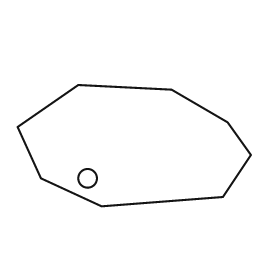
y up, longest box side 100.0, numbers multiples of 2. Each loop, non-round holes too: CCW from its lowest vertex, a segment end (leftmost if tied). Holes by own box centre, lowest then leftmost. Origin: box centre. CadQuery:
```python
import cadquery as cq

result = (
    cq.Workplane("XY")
    .moveTo(-14.0, -26.0)
    .lineTo(38.0, -22.0)
    .lineTo(50.0, -4.0)
    .lineTo(40.0, 10.0)
    .lineTo(16.0, 24.0)
    .lineTo(-24.0, 26.0)
    .lineTo(-50.0, 8.0)
    .lineTo(-40.0, -14.0)
    .close()
    .moveTo(-20.0, -14.0)
    .circle(4.0)
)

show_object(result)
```